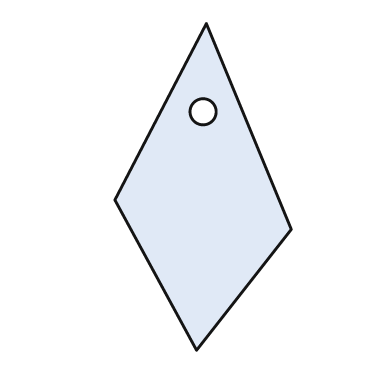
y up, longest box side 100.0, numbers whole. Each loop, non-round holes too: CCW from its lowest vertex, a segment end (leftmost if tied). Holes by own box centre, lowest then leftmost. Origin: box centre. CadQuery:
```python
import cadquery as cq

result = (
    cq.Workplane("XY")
    .moveTo(-2.0, -50.0)
    .lineTo(27.0, -13.0)
    .lineTo(1.0, 50.0)
    .lineTo(-27.0, -4.0)
    .close()
    .moveTo(0.0, 23.0)
    .circle(4.0)
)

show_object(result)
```